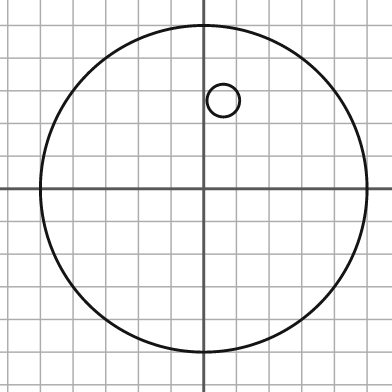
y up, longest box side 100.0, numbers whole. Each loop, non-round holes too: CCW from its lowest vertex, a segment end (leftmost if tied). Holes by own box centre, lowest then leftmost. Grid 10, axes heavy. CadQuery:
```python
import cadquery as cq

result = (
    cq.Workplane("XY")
    .moveTo(0.0, 0.0)
    .circle(50.0)
    .moveTo(6.0, 27.0)
    .circle(5.0)
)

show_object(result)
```